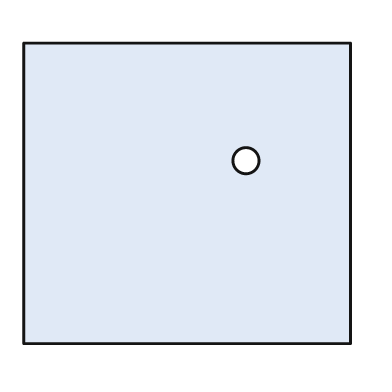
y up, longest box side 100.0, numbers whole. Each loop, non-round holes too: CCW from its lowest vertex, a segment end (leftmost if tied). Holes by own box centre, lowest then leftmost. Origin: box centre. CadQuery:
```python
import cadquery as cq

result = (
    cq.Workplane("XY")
    .moveTo(-50.0, -46.0)
    .lineTo(50.0, -46.0)
    .lineTo(50.0, 46.0)
    .lineTo(-50.0, 46.0)
    .close()
    .moveTo(18.0, 10.0)
    .circle(4.0)
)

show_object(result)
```